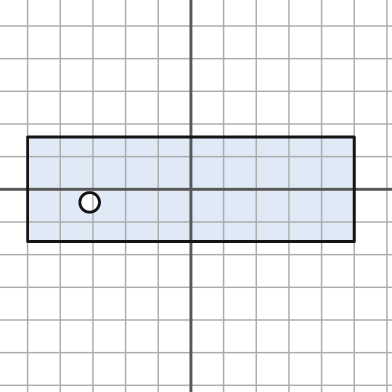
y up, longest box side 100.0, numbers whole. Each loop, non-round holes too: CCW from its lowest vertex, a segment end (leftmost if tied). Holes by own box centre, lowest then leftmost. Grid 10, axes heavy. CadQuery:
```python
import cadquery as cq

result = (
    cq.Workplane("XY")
    .moveTo(-50.0, -16.0)
    .lineTo(50.0, -16.0)
    .lineTo(50.0, 16.0)
    .lineTo(-50.0, 16.0)
    .close()
    .moveTo(-31.0, -4.0)
    .circle(3.0)
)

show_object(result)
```